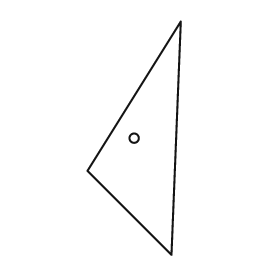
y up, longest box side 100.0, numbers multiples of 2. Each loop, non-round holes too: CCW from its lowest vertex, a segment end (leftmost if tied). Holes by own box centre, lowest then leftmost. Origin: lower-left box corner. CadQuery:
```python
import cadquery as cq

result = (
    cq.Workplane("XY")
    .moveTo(36.0, 0.0)
    .lineTo(40.0, 100.0)
    .lineTo(0.0, 36.0)
    .close()
    .moveTo(20.0, 50.0)
    .circle(2.0)
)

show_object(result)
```